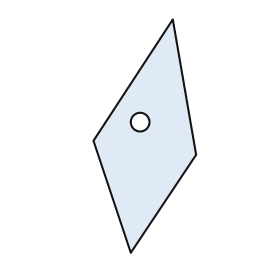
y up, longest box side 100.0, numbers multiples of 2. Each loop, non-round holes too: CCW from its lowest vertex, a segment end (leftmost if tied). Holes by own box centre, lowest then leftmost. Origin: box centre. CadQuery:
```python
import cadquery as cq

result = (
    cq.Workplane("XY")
    .moveTo(-6.0, -50.0)
    .lineTo(22.0, -8.0)
    .lineTo(12.0, 50.0)
    .lineTo(-22.0, -2.0)
    .close()
    .moveTo(-2.0, 6.0)
    .circle(4.0)
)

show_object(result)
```